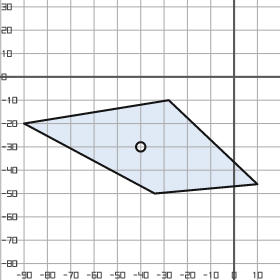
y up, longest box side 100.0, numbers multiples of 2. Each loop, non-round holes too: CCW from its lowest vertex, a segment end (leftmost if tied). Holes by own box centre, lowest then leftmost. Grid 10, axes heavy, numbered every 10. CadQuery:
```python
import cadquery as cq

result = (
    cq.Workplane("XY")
    .moveTo(-34.0, -50.0)
    .lineTo(10.0, -46.0)
    .lineTo(-28.0, -10.0)
    .lineTo(-90.0, -20.0)
    .close()
    .moveTo(-40.0, -30.0)
    .circle(2.0)
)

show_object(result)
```